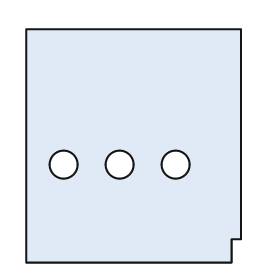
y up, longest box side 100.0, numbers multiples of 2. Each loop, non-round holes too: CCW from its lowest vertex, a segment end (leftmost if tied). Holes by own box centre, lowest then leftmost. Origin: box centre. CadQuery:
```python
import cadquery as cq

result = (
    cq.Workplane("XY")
    .moveTo(-46.0, -50.0)
    .lineTo(42.0, -50.0)
    .lineTo(42.0, -40.0)
    .lineTo(46.0, -40.0)
    .lineTo(46.0, 50.0)
    .lineTo(-46.0, 50.0)
    .close()
    .moveTo(-30.0, -8.0)
    .circle(6.0)
    .moveTo(-6.0, -8.0)
    .circle(6.0)
    .moveTo(18.0, -8.0)
    .circle(6.0)
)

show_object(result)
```